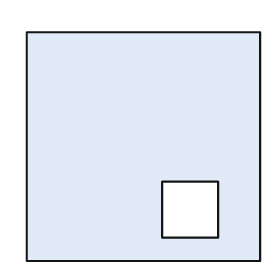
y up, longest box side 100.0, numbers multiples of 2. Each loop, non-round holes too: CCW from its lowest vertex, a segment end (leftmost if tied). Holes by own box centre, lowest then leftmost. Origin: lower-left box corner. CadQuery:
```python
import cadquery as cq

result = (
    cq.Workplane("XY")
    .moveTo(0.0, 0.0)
    .lineTo(100.0, 0.0)
    .lineTo(100.0, 98.0)
    .lineTo(0.0, 98.0)
    .close()
    .moveTo(58.0, 10.0)
    .lineTo(82.0, 10.0)
    .lineTo(82.0, 34.0)
    .lineTo(58.0, 34.0)
    .close()
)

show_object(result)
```